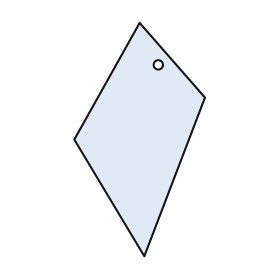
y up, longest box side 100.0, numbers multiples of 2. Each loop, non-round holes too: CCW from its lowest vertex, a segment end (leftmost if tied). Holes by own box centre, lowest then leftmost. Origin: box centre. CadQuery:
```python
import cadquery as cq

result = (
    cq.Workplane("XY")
    .moveTo(2.0, -50.0)
    .lineTo(28.0, 18.0)
    .lineTo(0.0, 50.0)
    .lineTo(-28.0, 0.0)
    .close()
    .moveTo(8.0, 32.0)
    .circle(2.0)
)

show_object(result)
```